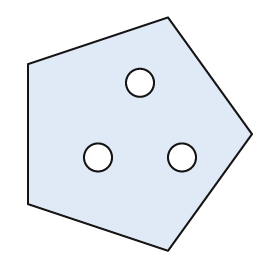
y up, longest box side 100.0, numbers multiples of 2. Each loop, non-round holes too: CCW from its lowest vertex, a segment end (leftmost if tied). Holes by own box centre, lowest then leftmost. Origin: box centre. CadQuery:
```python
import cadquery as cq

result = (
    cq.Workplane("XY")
    .moveTo(12.0, -50.0)
    .lineTo(48.0, 0.0)
    .lineTo(12.0, 50.0)
    .lineTo(-48.0, 30.0)
    .lineTo(-48.0, -30.0)
    .close()
    .moveTo(-18.0, -10.0)
    .circle(6.0)
    .moveTo(18.0, -10.0)
    .circle(6.0)
    .moveTo(0.0, 22.0)
    .circle(6.0)
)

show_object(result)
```